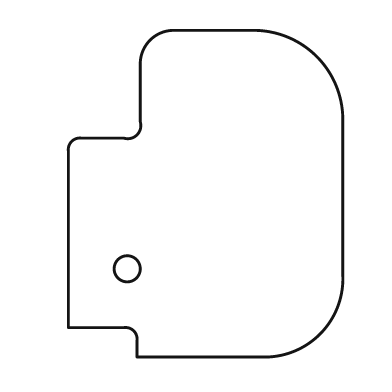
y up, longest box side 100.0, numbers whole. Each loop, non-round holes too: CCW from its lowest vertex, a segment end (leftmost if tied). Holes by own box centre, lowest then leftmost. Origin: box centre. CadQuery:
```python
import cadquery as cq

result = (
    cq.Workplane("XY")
    .moveTo(-21.0, -50.0)
    .lineTo(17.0, -50.0)
    .threePointArc((35.0, -43.0), (42.0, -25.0))
    .lineTo(42.0, 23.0)
    .threePointArc((34.0, 42.0), (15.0, 50.0))
    .lineTo(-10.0, 50.0)
    .threePointArc((-17.0, 47.0), (-20.0, 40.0))
    .lineTo(-20.0, 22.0)
    .threePointArc((-21.0, 18.0), (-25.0, 17.0))
    .lineTo(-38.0, 17.0)
    .threePointArc((-41.0, 16.0), (-42.0, 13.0))
    .lineTo(-42.0, -41.0)
    .lineTo(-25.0, -41.0)
    .threePointArc((-22.0, -42.0), (-21.0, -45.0))
    .close()
    .moveTo(-24.0, -23.0)
    .circle(4.0)
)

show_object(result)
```